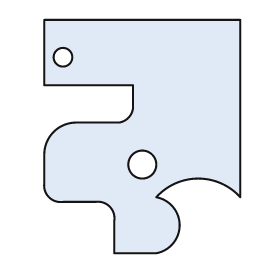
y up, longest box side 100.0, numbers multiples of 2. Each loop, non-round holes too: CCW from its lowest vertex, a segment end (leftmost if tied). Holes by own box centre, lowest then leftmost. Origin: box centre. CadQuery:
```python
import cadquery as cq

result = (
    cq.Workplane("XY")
    .moveTo(-12.0, -50.0)
    .lineTo(6.0, -50.0)
    .threePointArc((16.0, -38.0), (6.0, -26.0))
    .threePointArc((24.0, -18.0), (42.0, -26.0))
    .lineTo(42.0, 50.0)
    .lineTo(-42.0, 50.0)
    .lineTo(-42.0, 22.0)
    .lineTo(-4.0, 22.0)
    .lineTo(-4.0, 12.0)
    .threePointArc((-6.0, 8.0), (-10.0, 6.0))
    .lineTo(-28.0, 6.0)
    .threePointArc((-38.0, 2.0), (-42.0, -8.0))
    .lineTo(-42.0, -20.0)
    .threePointArc((-40.0, -26.0), (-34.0, -28.0))
    .lineTo(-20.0, -28.0)
    .threePointArc((-14.0, -30.0), (-12.0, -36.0))
    .close()
    .moveTo(0.0, -12.0)
    .circle(6.0)
    .moveTo(-34.0, 34.0)
    .circle(4.0)
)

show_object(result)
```